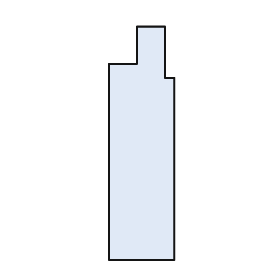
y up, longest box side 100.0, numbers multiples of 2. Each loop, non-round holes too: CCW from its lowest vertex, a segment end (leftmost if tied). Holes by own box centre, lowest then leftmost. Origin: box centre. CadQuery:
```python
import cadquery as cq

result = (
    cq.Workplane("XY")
    .moveTo(-14.0, -50.0)
    .lineTo(14.0, -50.0)
    .lineTo(14.0, 28.0)
    .lineTo(10.0, 28.0)
    .lineTo(10.0, 50.0)
    .lineTo(-2.0, 50.0)
    .lineTo(-2.0, 34.0)
    .lineTo(-14.0, 34.0)
    .close()
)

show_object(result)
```